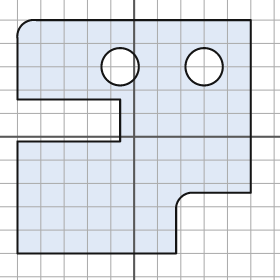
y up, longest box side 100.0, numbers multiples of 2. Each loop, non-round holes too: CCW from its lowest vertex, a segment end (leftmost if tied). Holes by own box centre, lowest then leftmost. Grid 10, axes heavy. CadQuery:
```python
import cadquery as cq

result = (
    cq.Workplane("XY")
    .moveTo(-50.0, -50.0)
    .lineTo(18.0, -50.0)
    .lineTo(18.0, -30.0)
    .threePointArc((20.0, -26.0), (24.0, -24.0))
    .lineTo(50.0, -24.0)
    .lineTo(50.0, 50.0)
    .lineTo(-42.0, 50.0)
    .threePointArc((-48.0, 48.0), (-50.0, 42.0))
    .lineTo(-50.0, 16.0)
    .lineTo(-6.0, 16.0)
    .lineTo(-6.0, -2.0)
    .lineTo(-50.0, -2.0)
    .close()
    .moveTo(-6.0, 30.0)
    .circle(8.0)
    .moveTo(30.0, 30.0)
    .circle(8.0)
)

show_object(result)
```